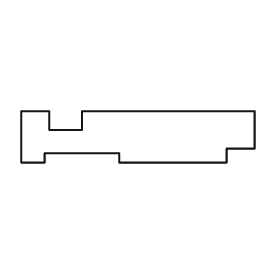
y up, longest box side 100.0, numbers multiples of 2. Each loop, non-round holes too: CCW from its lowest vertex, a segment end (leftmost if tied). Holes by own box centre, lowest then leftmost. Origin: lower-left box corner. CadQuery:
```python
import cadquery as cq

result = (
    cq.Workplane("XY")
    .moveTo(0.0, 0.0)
    .lineTo(10.0, 0.0)
    .lineTo(10.0, 4.0)
    .lineTo(42.0, 4.0)
    .lineTo(42.0, 0.0)
    .lineTo(88.0, 0.0)
    .lineTo(88.0, 6.0)
    .lineTo(100.0, 6.0)
    .lineTo(100.0, 22.0)
    .lineTo(26.0, 22.0)
    .lineTo(26.0, 14.0)
    .lineTo(12.0, 14.0)
    .lineTo(12.0, 22.0)
    .lineTo(0.0, 22.0)
    .close()
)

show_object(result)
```